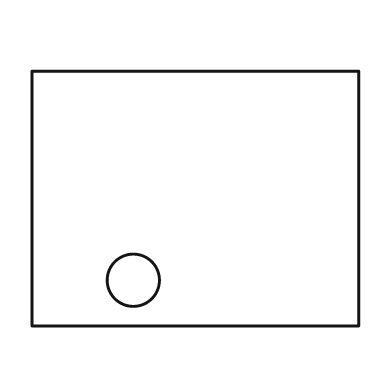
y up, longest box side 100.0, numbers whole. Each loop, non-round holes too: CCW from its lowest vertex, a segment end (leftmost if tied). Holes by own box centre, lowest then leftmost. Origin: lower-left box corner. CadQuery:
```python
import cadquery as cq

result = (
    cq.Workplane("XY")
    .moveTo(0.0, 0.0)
    .lineTo(100.0, 0.0)
    .lineTo(100.0, 78.0)
    .lineTo(0.0, 78.0)
    .close()
    .moveTo(31.0, 14.0)
    .circle(8.0)
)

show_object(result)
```